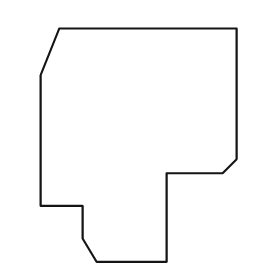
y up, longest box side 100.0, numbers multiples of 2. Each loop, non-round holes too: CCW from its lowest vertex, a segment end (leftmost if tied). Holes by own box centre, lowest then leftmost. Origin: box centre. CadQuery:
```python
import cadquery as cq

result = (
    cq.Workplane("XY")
    .moveTo(-18.0, -50.0)
    .lineTo(12.0, -50.0)
    .lineTo(12.0, -12.0)
    .lineTo(36.0, -12.0)
    .lineTo(42.0, -6.0)
    .lineTo(42.0, 50.0)
    .lineTo(-34.0, 50.0)
    .lineTo(-42.0, 30.0)
    .lineTo(-42.0, -26.0)
    .lineTo(-24.0, -26.0)
    .lineTo(-24.0, -40.0)
    .close()
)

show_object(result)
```